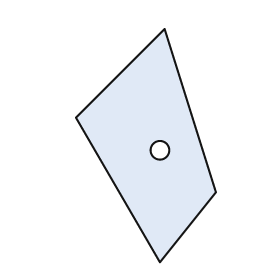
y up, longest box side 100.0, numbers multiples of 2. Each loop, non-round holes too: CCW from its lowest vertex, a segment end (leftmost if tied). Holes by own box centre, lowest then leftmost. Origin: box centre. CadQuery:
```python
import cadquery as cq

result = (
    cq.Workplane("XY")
    .moveTo(6.0, -50.0)
    .lineTo(30.0, -20.0)
    .lineTo(8.0, 50.0)
    .lineTo(-30.0, 12.0)
    .close()
    .moveTo(6.0, -2.0)
    .circle(4.0)
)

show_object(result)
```